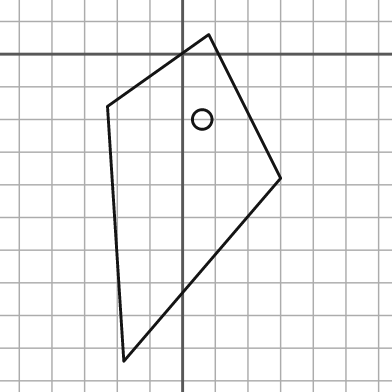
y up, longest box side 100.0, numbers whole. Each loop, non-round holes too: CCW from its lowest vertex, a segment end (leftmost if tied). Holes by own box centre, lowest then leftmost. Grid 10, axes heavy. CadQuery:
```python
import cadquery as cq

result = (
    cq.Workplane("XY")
    .moveTo(-18.0, -94.0)
    .lineTo(30.0, -38.0)
    .lineTo(8.0, 6.0)
    .lineTo(-23.0, -16.0)
    .close()
    .moveTo(6.0, -20.0)
    .circle(3.0)
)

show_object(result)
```